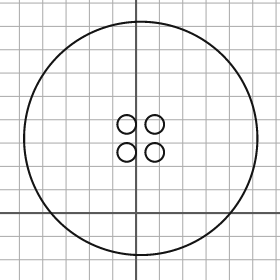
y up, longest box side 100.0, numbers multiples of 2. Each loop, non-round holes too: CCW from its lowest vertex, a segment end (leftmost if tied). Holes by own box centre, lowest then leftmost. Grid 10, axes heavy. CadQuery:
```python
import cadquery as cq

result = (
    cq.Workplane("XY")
    .moveTo(2.0, 32.0)
    .circle(50.0)
    .moveTo(-4.0, 26.0)
    .circle(4.0)
    .moveTo(8.0, 26.0)
    .circle(4.0)
    .moveTo(-4.0, 38.0)
    .circle(4.0)
    .moveTo(8.0, 38.0)
    .circle(4.0)
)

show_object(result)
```